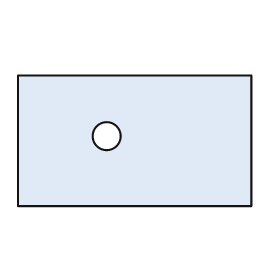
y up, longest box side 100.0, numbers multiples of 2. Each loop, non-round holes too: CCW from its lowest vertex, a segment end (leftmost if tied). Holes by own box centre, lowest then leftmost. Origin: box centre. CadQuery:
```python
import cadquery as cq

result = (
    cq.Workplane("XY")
    .moveTo(-50.0, -28.0)
    .lineTo(50.0, -28.0)
    .lineTo(50.0, 28.0)
    .lineTo(-50.0, 28.0)
    .close()
    .moveTo(-12.0, 2.0)
    .circle(6.0)
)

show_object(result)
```